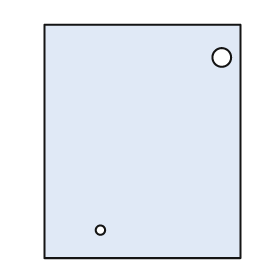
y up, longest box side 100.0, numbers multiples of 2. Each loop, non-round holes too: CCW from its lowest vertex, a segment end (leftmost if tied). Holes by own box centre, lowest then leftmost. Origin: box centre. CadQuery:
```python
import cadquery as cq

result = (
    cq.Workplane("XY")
    .moveTo(-42.0, -50.0)
    .lineTo(42.0, -50.0)
    .lineTo(42.0, 50.0)
    .lineTo(-42.0, 50.0)
    .close()
    .moveTo(-18.0, -38.0)
    .circle(2.0)
    .moveTo(34.0, 36.0)
    .circle(4.0)
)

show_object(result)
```